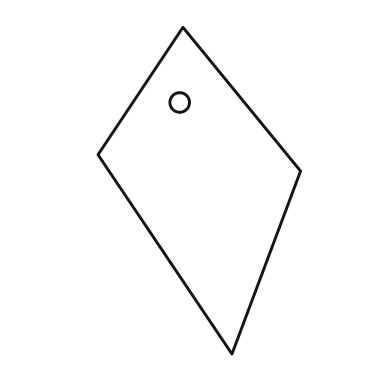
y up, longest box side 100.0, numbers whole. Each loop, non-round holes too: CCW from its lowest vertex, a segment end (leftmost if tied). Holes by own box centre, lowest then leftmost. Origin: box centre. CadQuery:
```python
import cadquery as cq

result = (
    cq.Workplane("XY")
    .moveTo(10.0, -50.0)
    .lineTo(31.0, 6.0)
    .lineTo(-5.0, 50.0)
    .lineTo(-31.0, 11.0)
    .close()
    .moveTo(-6.0, 27.0)
    .circle(3.0)
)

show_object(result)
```